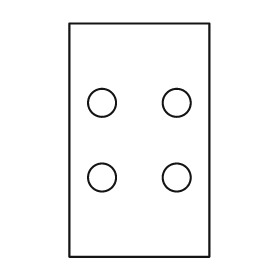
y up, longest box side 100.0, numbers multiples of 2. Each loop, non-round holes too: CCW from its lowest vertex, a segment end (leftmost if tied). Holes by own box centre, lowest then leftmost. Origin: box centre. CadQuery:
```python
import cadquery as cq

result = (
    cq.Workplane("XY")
    .moveTo(-30.0, -50.0)
    .lineTo(30.0, -50.0)
    .lineTo(30.0, 50.0)
    .lineTo(-30.0, 50.0)
    .close()
    .moveTo(-16.0, -16.0)
    .circle(6.0)
    .moveTo(16.0, -16.0)
    .circle(6.0)
    .moveTo(-16.0, 16.0)
    .circle(6.0)
    .moveTo(16.0, 16.0)
    .circle(6.0)
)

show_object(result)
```